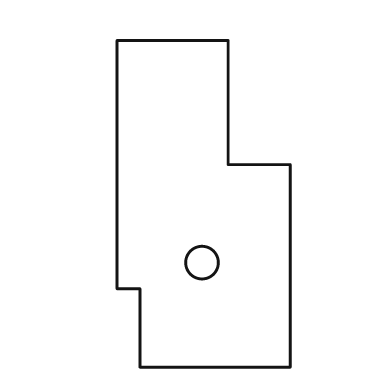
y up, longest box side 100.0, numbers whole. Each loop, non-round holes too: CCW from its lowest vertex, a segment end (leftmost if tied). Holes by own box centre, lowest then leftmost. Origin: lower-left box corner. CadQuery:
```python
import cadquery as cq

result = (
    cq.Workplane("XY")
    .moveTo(7.0, 0.0)
    .lineTo(53.0, 0.0)
    .lineTo(53.0, 62.0)
    .lineTo(34.0, 62.0)
    .lineTo(34.0, 100.0)
    .lineTo(0.0, 100.0)
    .lineTo(0.0, 24.0)
    .lineTo(7.0, 24.0)
    .close()
    .moveTo(26.0, 32.0)
    .circle(5.0)
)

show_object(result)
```